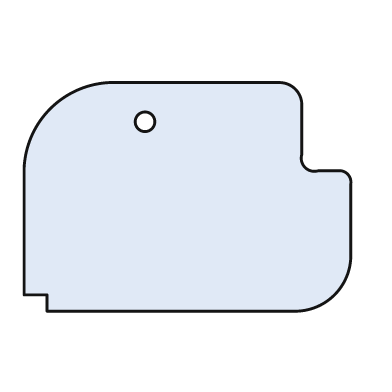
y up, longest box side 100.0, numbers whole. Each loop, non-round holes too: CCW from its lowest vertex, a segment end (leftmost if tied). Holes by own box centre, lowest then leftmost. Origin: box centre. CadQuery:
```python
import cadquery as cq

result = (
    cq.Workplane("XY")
    .moveTo(-43.0, -35.0)
    .lineTo(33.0, -35.0)
    .threePointArc((45.0, -30.0), (50.0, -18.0))
    .lineTo(50.0, 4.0)
    .threePointArc((49.0, 7.0), (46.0, 8.0))
    .lineTo(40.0, 8.0)
    .threePointArc((36.0, 9.0), (35.0, 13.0))
    .lineTo(35.0, 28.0)
    .threePointArc((33.0, 33.0), (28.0, 35.0))
    .lineTo(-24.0, 35.0)
    .threePointArc((-42.0, 27.0), (-50.0, 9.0))
    .lineTo(-50.0, -30.0)
    .lineTo(-43.0, -30.0)
    .close()
    .moveTo(-13.0, 23.0)
    .circle(3.0)
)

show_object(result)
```